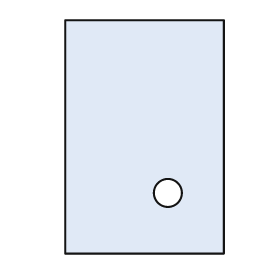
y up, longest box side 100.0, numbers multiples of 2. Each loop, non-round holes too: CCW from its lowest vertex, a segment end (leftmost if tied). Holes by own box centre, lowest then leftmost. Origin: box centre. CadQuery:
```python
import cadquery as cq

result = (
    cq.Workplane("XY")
    .moveTo(-34.0, -50.0)
    .lineTo(34.0, -50.0)
    .lineTo(34.0, 50.0)
    .lineTo(-34.0, 50.0)
    .close()
    .moveTo(10.0, -24.0)
    .circle(6.0)
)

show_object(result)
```